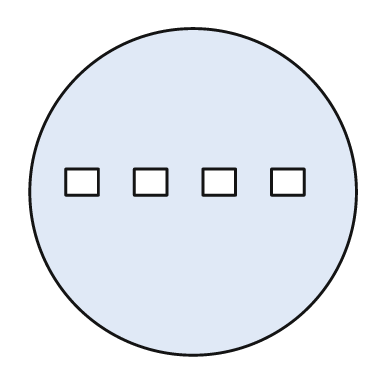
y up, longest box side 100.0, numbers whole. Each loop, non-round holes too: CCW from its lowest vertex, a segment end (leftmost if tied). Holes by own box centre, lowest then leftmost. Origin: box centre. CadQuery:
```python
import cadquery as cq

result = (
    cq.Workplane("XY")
    .moveTo(0.0, 0.0)
    .circle(50.0)
    .moveTo(-39.0, -1.0)
    .lineTo(-29.0, -1.0)
    .lineTo(-29.0, 7.0)
    .lineTo(-39.0, 7.0)
    .close()
    .moveTo(-18.0, -1.0)
    .lineTo(-8.0, -1.0)
    .lineTo(-8.0, 7.0)
    .lineTo(-18.0, 7.0)
    .close()
    .moveTo(3.0, -1.0)
    .lineTo(13.0, -1.0)
    .lineTo(13.0, 7.0)
    .lineTo(3.0, 7.0)
    .close()
    .moveTo(24.0, -1.0)
    .lineTo(34.0, -1.0)
    .lineTo(34.0, 7.0)
    .lineTo(24.0, 7.0)
    .close()
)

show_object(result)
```